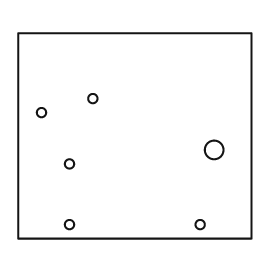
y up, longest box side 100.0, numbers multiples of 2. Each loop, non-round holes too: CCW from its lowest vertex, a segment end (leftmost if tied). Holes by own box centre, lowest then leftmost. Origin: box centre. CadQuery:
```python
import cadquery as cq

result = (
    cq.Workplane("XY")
    .moveTo(-50.0, -44.0)
    .lineTo(50.0, -44.0)
    .lineTo(50.0, 44.0)
    .lineTo(-50.0, 44.0)
    .close()
    .moveTo(-28.0, -38.0)
    .circle(2.0)
    .moveTo(28.0, -38.0)
    .circle(2.0)
    .moveTo(-28.0, -12.0)
    .circle(2.0)
    .moveTo(34.0, -6.0)
    .circle(4.0)
    .moveTo(-40.0, 10.0)
    .circle(2.0)
    .moveTo(-18.0, 16.0)
    .circle(2.0)
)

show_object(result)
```